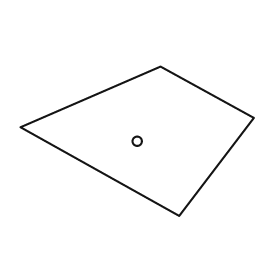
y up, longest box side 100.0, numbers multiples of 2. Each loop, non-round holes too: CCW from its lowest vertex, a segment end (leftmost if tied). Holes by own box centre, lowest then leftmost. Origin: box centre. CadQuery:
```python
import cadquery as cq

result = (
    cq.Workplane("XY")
    .moveTo(18.0, -32.0)
    .lineTo(50.0, 10.0)
    .lineTo(10.0, 32.0)
    .lineTo(-50.0, 6.0)
    .close()
    .moveTo(0.0, 0.0)
    .circle(2.0)
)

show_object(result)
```